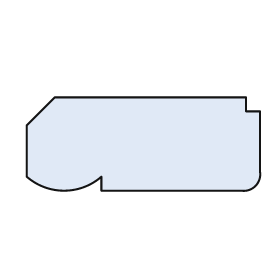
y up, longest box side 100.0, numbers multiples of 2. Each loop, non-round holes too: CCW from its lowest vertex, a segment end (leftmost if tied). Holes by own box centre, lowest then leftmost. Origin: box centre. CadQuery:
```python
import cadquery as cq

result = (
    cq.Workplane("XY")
    .moveTo(-18.0, -20.0)
    .lineTo(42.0, -20.0)
    .threePointArc((48.0, -18.0), (50.0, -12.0))
    .lineTo(50.0, 14.0)
    .lineTo(44.0, 14.0)
    .lineTo(44.0, 20.0)
    .lineTo(-38.0, 20.0)
    .lineTo(-50.0, 8.0)
    .lineTo(-50.0, -14.0)
    .threePointArc((-34.0, -20.0), (-18.0, -14.0))
    .close()
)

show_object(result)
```